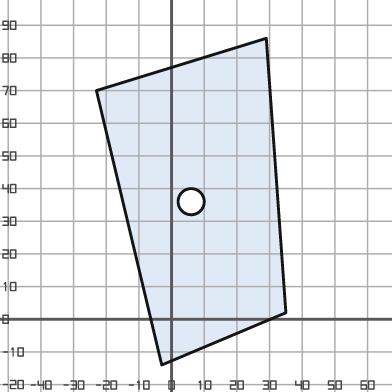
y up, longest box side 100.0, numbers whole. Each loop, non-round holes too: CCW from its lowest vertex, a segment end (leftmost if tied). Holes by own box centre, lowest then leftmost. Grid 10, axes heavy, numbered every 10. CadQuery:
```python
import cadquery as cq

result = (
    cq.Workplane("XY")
    .moveTo(-3.0, -14.0)
    .lineTo(35.0, 2.0)
    .lineTo(29.0, 86.0)
    .lineTo(-23.0, 70.0)
    .close()
    .moveTo(6.0, 36.0)
    .circle(4.0)
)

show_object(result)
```